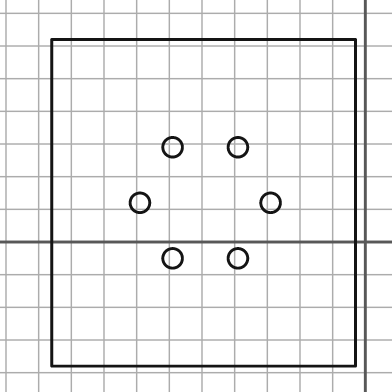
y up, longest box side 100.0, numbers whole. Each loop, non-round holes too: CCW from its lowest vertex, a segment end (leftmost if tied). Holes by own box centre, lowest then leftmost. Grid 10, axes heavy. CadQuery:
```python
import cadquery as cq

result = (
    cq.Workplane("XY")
    .moveTo(-96.0, -38.0)
    .lineTo(-3.0, -38.0)
    .lineTo(-3.0, 62.0)
    .lineTo(-96.0, 62.0)
    .close()
    .moveTo(-59.0, -5.0)
    .circle(3.0)
    .moveTo(-39.0, -5.0)
    .circle(3.0)
    .moveTo(-69.0, 12.0)
    .circle(3.0)
    .moveTo(-29.0, 12.0)
    .circle(3.0)
    .moveTo(-59.0, 29.0)
    .circle(3.0)
    .moveTo(-39.0, 29.0)
    .circle(3.0)
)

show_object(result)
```